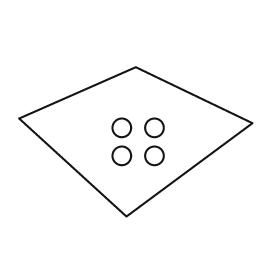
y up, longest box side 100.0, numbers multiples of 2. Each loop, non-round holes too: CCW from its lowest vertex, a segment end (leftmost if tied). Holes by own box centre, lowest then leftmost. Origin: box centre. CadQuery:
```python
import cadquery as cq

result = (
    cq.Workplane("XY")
    .moveTo(-4.0, -32.0)
    .lineTo(50.0, 8.0)
    .lineTo(0.0, 32.0)
    .lineTo(-50.0, 10.0)
    .close()
    .moveTo(-6.0, -6.0)
    .circle(4.0)
    .moveTo(8.0, -6.0)
    .circle(4.0)
    .moveTo(-6.0, 6.0)
    .circle(4.0)
    .moveTo(8.0, 6.0)
    .circle(4.0)
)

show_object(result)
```